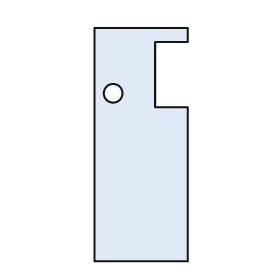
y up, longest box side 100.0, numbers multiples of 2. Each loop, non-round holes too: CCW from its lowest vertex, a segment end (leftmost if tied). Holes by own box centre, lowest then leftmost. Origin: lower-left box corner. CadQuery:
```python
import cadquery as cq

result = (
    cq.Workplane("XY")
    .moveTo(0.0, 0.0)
    .lineTo(40.0, 0.0)
    .lineTo(40.0, 66.0)
    .lineTo(26.0, 66.0)
    .lineTo(26.0, 94.0)
    .lineTo(40.0, 94.0)
    .lineTo(40.0, 100.0)
    .lineTo(0.0, 100.0)
    .close()
    .moveTo(8.0, 72.0)
    .circle(4.0)
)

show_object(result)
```